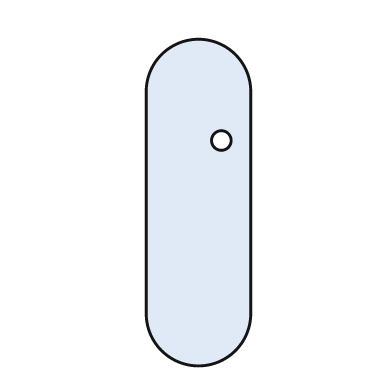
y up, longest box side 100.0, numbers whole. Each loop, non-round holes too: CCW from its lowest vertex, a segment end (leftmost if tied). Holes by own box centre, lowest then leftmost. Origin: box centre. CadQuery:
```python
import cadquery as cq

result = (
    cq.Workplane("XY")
    .moveTo(-16.0, -34.0)
    .threePointArc((0.0, -50.0), (16.0, -34.0))
    .lineTo(16.0, 34.0)
    .threePointArc((0.0, 50.0), (-16.0, 34.0))
    .close()
    .moveTo(7.0, 19.0)
    .circle(3.0)
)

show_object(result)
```